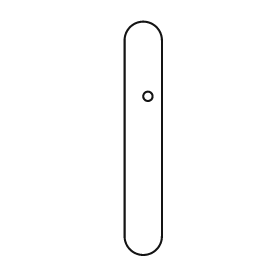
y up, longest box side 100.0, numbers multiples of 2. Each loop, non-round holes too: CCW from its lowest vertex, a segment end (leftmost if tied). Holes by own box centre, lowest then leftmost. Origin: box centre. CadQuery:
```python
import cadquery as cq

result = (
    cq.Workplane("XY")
    .moveTo(-8.0, -42.0)
    .threePointArc((0.0, -50.0), (8.0, -42.0))
    .lineTo(8.0, 42.0)
    .threePointArc((0.0, 50.0), (-8.0, 42.0))
    .close()
    .moveTo(2.0, 18.0)
    .circle(2.0)
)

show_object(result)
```